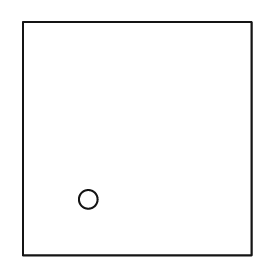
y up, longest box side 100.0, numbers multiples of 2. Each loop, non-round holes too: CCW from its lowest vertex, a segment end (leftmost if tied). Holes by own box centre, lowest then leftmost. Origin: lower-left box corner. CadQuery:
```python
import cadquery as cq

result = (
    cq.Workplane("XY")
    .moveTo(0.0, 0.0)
    .lineTo(98.0, 0.0)
    .lineTo(98.0, 100.0)
    .lineTo(0.0, 100.0)
    .close()
    .moveTo(28.0, 24.0)
    .circle(4.0)
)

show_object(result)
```